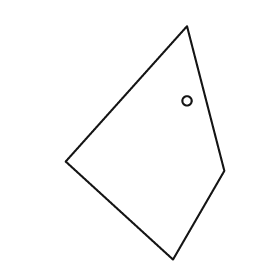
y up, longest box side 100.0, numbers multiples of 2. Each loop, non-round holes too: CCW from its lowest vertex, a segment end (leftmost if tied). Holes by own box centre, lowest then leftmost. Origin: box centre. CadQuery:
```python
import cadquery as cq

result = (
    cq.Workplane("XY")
    .moveTo(12.0, -50.0)
    .lineTo(34.0, -12.0)
    .lineTo(18.0, 50.0)
    .lineTo(-34.0, -8.0)
    .close()
    .moveTo(18.0, 18.0)
    .circle(2.0)
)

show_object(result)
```